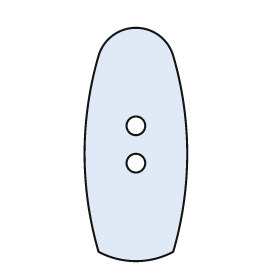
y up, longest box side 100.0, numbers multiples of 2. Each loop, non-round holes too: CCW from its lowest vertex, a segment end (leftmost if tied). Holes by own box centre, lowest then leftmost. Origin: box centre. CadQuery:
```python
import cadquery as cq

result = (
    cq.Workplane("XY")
    .moveTo(-16.0, -46.0)
    .threePointArc((0.0, -50.0), (16.0, -46.0))
    .threePointArc((22.0, -4.0), (16.0, 38.0))
    .threePointArc((0.0, 50.0), (-16.0, 38.0))
    .threePointArc((-22.0, -4.0), (-16.0, -46.0))
    .close()
    .moveTo(0.0, -8.0)
    .circle(4.0)
    .moveTo(0.0, 8.0)
    .circle(4.0)
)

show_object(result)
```